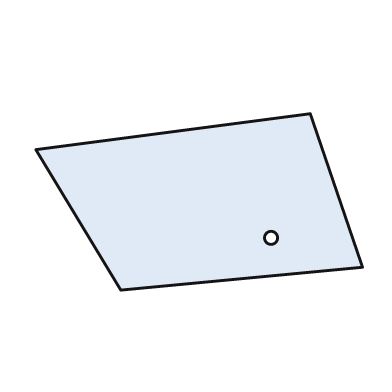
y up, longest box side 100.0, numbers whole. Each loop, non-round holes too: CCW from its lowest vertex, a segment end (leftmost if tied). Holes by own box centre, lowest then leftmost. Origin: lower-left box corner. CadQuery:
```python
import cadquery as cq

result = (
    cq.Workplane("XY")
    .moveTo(26.0, 0.0)
    .lineTo(100.0, 7.0)
    .lineTo(84.0, 54.0)
    .lineTo(0.0, 43.0)
    .close()
    .moveTo(72.0, 16.0)
    .circle(2.0)
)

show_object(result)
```